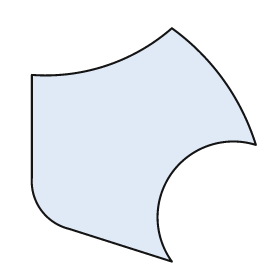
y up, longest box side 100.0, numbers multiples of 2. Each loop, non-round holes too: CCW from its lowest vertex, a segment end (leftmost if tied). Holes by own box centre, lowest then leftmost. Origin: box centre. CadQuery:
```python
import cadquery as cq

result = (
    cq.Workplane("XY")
    .moveTo(12.0, -50.0)
    .threePointArc((12.0, -12.0), (48.0, 0.0))
    .threePointArc((34.0, 28.0), (12.0, 50.0))
    .threePointArc((-16.0, 34.0), (-48.0, 30.0))
    .lineTo(-48.0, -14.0)
    .threePointArc((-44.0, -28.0), (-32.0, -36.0))
    .close()
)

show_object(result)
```